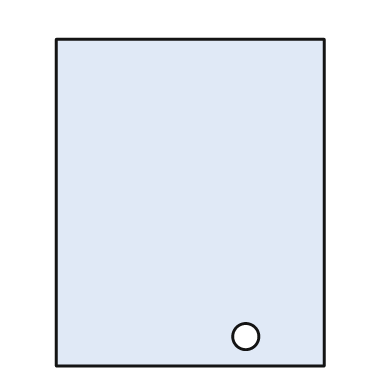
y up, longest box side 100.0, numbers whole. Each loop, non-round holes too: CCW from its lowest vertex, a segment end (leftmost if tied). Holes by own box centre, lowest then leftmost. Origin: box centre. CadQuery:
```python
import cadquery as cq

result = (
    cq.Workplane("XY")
    .moveTo(-41.0, -50.0)
    .lineTo(41.0, -50.0)
    .lineTo(41.0, 50.0)
    .lineTo(-41.0, 50.0)
    .close()
    .moveTo(17.0, -41.0)
    .circle(4.0)
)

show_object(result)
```